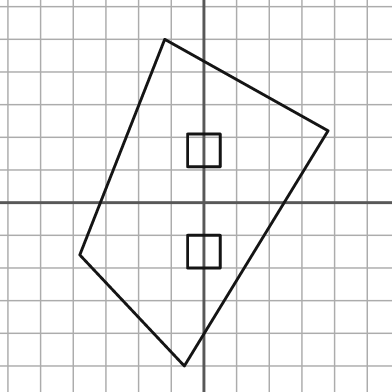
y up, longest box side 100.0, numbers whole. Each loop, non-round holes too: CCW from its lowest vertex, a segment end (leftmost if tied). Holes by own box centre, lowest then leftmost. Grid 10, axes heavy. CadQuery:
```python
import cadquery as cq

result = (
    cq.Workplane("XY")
    .moveTo(-6.0, -50.0)
    .lineTo(38.0, 22.0)
    .lineTo(-12.0, 50.0)
    .lineTo(-38.0, -16.0)
    .close()
    .moveTo(-5.0, -20.0)
    .lineTo(5.0, -20.0)
    .lineTo(5.0, -10.0)
    .lineTo(-5.0, -10.0)
    .close()
    .moveTo(-5.0, 11.0)
    .lineTo(5.0, 11.0)
    .lineTo(5.0, 21.0)
    .lineTo(-5.0, 21.0)
    .close()
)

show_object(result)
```